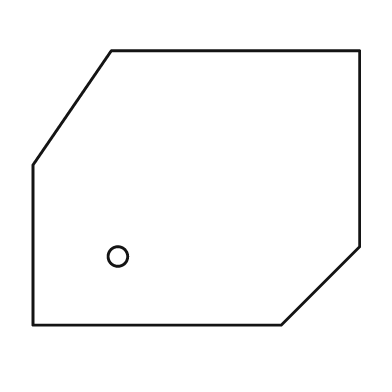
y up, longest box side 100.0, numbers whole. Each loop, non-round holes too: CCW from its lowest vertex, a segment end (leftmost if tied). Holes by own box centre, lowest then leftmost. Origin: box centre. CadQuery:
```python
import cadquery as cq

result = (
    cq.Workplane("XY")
    .moveTo(-50.0, -42.0)
    .lineTo(26.0, -42.0)
    .lineTo(50.0, -18.0)
    .lineTo(50.0, 42.0)
    .lineTo(-26.0, 42.0)
    .lineTo(-50.0, 7.0)
    .close()
    .moveTo(-24.0, -21.0)
    .circle(3.0)
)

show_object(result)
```